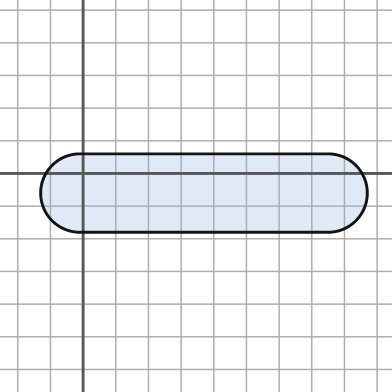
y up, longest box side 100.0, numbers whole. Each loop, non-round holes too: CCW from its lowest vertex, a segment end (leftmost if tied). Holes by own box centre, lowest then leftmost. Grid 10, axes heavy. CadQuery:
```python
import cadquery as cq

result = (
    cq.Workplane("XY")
    .moveTo(-1.0, -18.0)
    .lineTo(75.0, -18.0)
    .threePointArc((87.0, -6.0), (75.0, 6.0))
    .lineTo(-1.0, 6.0)
    .threePointArc((-13.0, -6.0), (-1.0, -18.0))
    .close()
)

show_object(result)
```